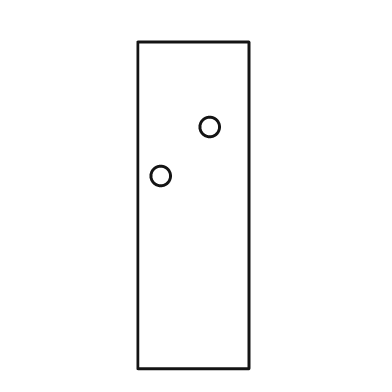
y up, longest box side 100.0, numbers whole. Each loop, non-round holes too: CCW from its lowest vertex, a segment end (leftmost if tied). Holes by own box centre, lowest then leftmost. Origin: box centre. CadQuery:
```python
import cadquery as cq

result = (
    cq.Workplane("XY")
    .moveTo(-17.0, -50.0)
    .lineTo(17.0, -50.0)
    .lineTo(17.0, 50.0)
    .lineTo(-17.0, 50.0)
    .close()
    .moveTo(-10.0, 9.0)
    .circle(3.0)
    .moveTo(5.0, 24.0)
    .circle(3.0)
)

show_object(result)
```